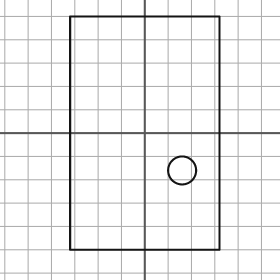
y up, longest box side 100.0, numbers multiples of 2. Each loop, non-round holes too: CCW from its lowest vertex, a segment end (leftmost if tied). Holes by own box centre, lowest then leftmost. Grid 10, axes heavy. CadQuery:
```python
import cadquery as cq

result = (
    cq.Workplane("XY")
    .moveTo(-32.0, -50.0)
    .lineTo(32.0, -50.0)
    .lineTo(32.0, 50.0)
    .lineTo(-32.0, 50.0)
    .close()
    .moveTo(16.0, -16.0)
    .circle(6.0)
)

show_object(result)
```